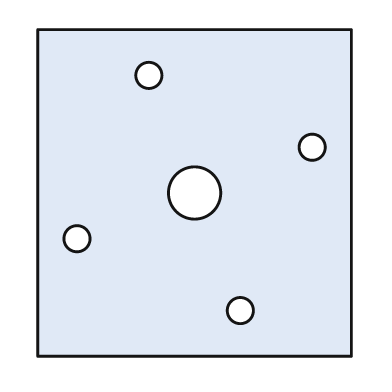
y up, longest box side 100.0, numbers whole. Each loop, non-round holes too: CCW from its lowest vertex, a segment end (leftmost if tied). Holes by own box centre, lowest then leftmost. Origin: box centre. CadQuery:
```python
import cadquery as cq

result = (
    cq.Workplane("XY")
    .moveTo(-48.0, -50.0)
    .lineTo(48.0, -50.0)
    .lineTo(48.0, 50.0)
    .lineTo(-48.0, 50.0)
    .close()
    .moveTo(14.0, -36.0)
    .circle(4.0)
    .moveTo(-36.0, -14.0)
    .circle(4.0)
    .moveTo(0.0, 0.0)
    .circle(8.0)
    .moveTo(36.0, 14.0)
    .circle(4.0)
    .moveTo(-14.0, 36.0)
    .circle(4.0)
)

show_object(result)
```